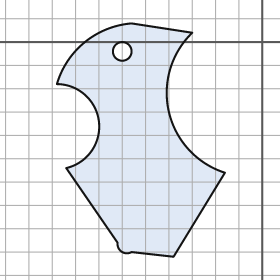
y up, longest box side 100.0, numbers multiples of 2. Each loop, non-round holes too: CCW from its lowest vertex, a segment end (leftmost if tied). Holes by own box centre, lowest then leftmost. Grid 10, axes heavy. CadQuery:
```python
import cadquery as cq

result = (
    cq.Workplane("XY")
    .moveTo(-38.0, -92.0)
    .lineTo(-16.0, -56.0)
    .threePointArc((-40.0, -30.0), (-30.0, 4.0))
    .lineTo(-56.0, 8.0)
    .threePointArc((-76.0, 0.0), (-88.0, -18.0))
    .threePointArc((-70.0, -34.0), (-84.0, -54.0))
    .lineTo(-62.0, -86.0)
    .threePointArc((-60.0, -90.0), (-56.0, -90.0))
    .close()
    .moveTo(-60.0, -4.0)
    .circle(4.0)
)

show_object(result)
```